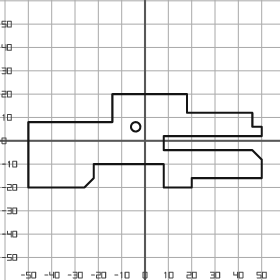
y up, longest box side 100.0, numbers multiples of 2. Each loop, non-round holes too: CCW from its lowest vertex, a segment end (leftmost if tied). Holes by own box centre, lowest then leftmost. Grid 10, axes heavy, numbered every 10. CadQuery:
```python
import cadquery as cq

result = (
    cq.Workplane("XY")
    .moveTo(-50.0, -20.0)
    .lineTo(-26.0, -20.0)
    .lineTo(-22.0, -16.0)
    .lineTo(-22.0, -10.0)
    .lineTo(8.0, -10.0)
    .lineTo(8.0, -20.0)
    .lineTo(20.0, -20.0)
    .lineTo(20.0, -16.0)
    .lineTo(50.0, -16.0)
    .lineTo(50.0, -8.0)
    .lineTo(46.0, -4.0)
    .lineTo(8.0, -4.0)
    .lineTo(8.0, 2.0)
    .lineTo(50.0, 2.0)
    .lineTo(50.0, 6.0)
    .lineTo(46.0, 6.0)
    .lineTo(46.0, 12.0)
    .lineTo(18.0, 12.0)
    .lineTo(18.0, 20.0)
    .lineTo(-14.0, 20.0)
    .lineTo(-14.0, 8.0)
    .lineTo(-50.0, 8.0)
    .close()
    .moveTo(-4.0, 6.0)
    .circle(2.0)
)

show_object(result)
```